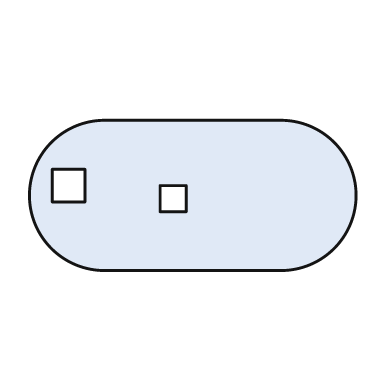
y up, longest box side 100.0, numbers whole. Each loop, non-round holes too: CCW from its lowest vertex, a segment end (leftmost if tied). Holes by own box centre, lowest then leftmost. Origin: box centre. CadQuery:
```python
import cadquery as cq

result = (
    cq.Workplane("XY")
    .moveTo(-27.0, -23.0)
    .lineTo(27.0, -23.0)
    .threePointArc((50.0, 0.0), (27.0, 23.0))
    .lineTo(-27.0, 23.0)
    .threePointArc((-50.0, 0.0), (-27.0, -23.0))
    .close()
    .moveTo(-10.0, -5.0)
    .lineTo(-2.0, -5.0)
    .lineTo(-2.0, 3.0)
    .lineTo(-10.0, 3.0)
    .close()
    .moveTo(-43.0, -2.0)
    .lineTo(-33.0, -2.0)
    .lineTo(-33.0, 8.0)
    .lineTo(-43.0, 8.0)
    .close()
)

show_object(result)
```